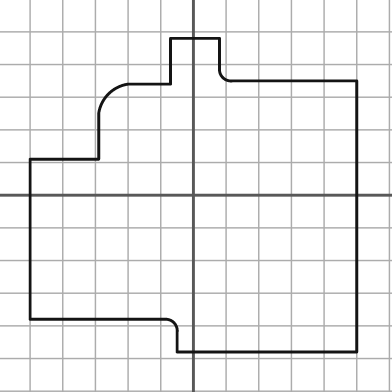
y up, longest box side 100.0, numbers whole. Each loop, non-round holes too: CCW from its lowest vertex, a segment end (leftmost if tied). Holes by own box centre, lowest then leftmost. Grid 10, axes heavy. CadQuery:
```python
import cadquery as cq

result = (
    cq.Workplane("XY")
    .moveTo(-5.0, -48.0)
    .lineTo(50.0, -48.0)
    .lineTo(50.0, 35.0)
    .lineTo(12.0, 35.0)
    .threePointArc((9.0, 36.0), (8.0, 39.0))
    .lineTo(8.0, 48.0)
    .lineTo(-7.0, 48.0)
    .lineTo(-7.0, 34.0)
    .lineTo(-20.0, 34.0)
    .threePointArc((-26.0, 31.0), (-29.0, 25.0))
    .lineTo(-29.0, 11.0)
    .lineTo(-50.0, 11.0)
    .lineTo(-50.0, -38.0)
    .lineTo(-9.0, -38.0)
    .threePointArc((-6.0, -39.0), (-5.0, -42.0))
    .close()
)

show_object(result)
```